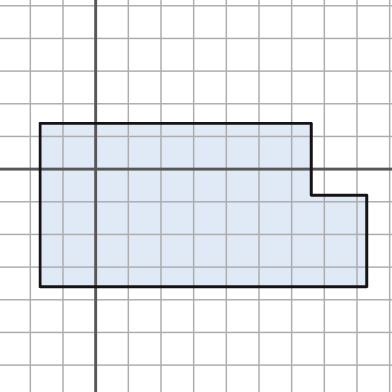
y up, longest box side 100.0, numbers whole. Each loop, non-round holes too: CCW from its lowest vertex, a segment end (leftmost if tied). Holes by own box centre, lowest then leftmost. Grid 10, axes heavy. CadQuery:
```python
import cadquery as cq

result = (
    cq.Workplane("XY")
    .moveTo(-17.0, -36.0)
    .lineTo(83.0, -36.0)
    .lineTo(83.0, -8.0)
    .lineTo(66.0, -8.0)
    .lineTo(66.0, 14.0)
    .lineTo(-17.0, 14.0)
    .close()
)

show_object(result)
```